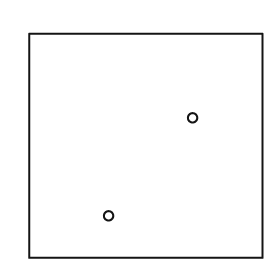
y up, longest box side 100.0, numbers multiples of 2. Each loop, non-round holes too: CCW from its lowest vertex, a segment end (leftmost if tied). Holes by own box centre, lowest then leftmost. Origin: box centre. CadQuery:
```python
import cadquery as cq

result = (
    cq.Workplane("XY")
    .moveTo(-50.0, -48.0)
    .lineTo(50.0, -48.0)
    .lineTo(50.0, 48.0)
    .lineTo(-50.0, 48.0)
    .close()
    .moveTo(-16.0, -30.0)
    .circle(2.0)
    .moveTo(20.0, 12.0)
    .circle(2.0)
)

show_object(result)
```